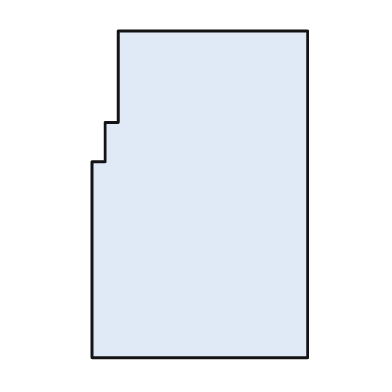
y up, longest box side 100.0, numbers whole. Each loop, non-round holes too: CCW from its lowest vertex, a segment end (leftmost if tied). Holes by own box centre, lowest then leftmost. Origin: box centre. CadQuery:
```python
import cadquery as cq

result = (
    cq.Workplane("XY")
    .moveTo(-33.0, -50.0)
    .lineTo(33.0, -50.0)
    .lineTo(33.0, 50.0)
    .lineTo(-25.0, 50.0)
    .lineTo(-25.0, 22.0)
    .lineTo(-29.0, 22.0)
    .lineTo(-29.0, 10.0)
    .lineTo(-33.0, 10.0)
    .close()
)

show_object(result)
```